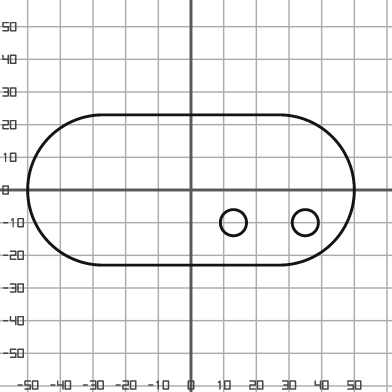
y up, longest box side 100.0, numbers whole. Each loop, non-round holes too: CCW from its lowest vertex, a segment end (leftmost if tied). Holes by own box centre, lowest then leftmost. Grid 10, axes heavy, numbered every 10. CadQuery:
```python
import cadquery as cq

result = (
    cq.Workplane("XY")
    .moveTo(-27.0, -23.0)
    .lineTo(27.0, -23.0)
    .threePointArc((50.0, 0.0), (27.0, 23.0))
    .lineTo(-27.0, 23.0)
    .threePointArc((-50.0, 0.0), (-27.0, -23.0))
    .close()
    .moveTo(13.0, -10.0)
    .circle(4.0)
    .moveTo(35.0, -10.0)
    .circle(4.0)
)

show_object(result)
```